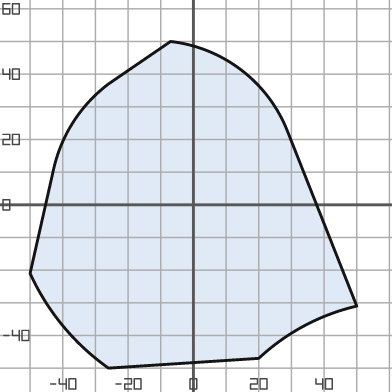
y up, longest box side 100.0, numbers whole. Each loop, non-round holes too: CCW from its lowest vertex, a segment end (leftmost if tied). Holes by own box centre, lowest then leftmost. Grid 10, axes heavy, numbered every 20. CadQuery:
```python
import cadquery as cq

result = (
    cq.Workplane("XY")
    .moveTo(-26.0, -50.0)
    .lineTo(20.0, -47.0)
    .threePointArc((34.0, -37.0), (50.0, -31.0))
    .lineTo(29.0, 22.0)
    .threePointArc((15.0, 41.0), (-7.0, 50.0))
    .lineTo(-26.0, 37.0)
    .threePointArc((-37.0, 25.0), (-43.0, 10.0))
    .lineTo(-50.0, -21.0)
    .threePointArc((-40.0, -37.0), (-26.0, -50.0))
    .close()
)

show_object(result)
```